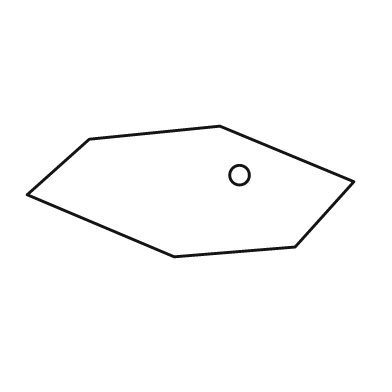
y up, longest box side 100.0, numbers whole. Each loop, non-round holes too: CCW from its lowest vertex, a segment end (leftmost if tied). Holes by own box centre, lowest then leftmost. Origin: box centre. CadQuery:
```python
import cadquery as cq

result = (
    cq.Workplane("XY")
    .moveTo(-5.0, -20.0)
    .lineTo(32.0, -17.0)
    .lineTo(50.0, 3.0)
    .lineTo(9.0, 20.0)
    .lineTo(-31.0, 16.0)
    .lineTo(-50.0, -1.0)
    .close()
    .moveTo(15.0, 5.0)
    .circle(3.0)
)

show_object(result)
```